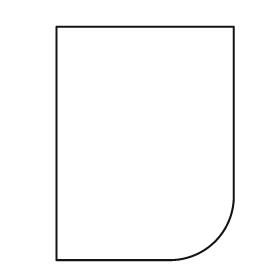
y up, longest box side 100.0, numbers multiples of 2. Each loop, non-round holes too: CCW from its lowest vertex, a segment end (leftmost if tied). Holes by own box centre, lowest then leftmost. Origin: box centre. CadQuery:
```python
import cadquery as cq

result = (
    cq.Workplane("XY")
    .moveTo(-38.0, -50.0)
    .lineTo(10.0, -50.0)
    .threePointArc((30.0, -42.0), (38.0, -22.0))
    .lineTo(38.0, 50.0)
    .lineTo(-38.0, 50.0)
    .close()
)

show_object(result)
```